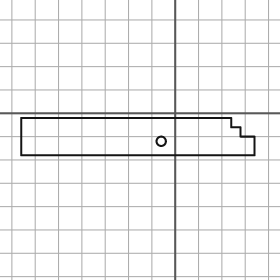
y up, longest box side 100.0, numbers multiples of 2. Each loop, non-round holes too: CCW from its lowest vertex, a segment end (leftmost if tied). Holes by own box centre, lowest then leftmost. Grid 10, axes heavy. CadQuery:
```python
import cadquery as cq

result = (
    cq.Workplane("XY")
    .moveTo(-66.0, -18.0)
    .lineTo(34.0, -18.0)
    .lineTo(34.0, -10.0)
    .lineTo(28.0, -10.0)
    .lineTo(28.0, -6.0)
    .lineTo(24.0, -6.0)
    .lineTo(24.0, -2.0)
    .lineTo(-66.0, -2.0)
    .close()
    .moveTo(-6.0, -12.0)
    .circle(2.0)
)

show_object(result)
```